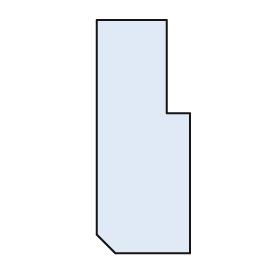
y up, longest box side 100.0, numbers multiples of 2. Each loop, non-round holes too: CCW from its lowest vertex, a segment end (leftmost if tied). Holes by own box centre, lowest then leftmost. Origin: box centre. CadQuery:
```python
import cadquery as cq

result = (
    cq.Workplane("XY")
    .moveTo(-12.0, -50.0)
    .lineTo(20.0, -50.0)
    .lineTo(20.0, 10.0)
    .lineTo(10.0, 10.0)
    .lineTo(10.0, 50.0)
    .lineTo(-20.0, 50.0)
    .lineTo(-20.0, -42.0)
    .close()
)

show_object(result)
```